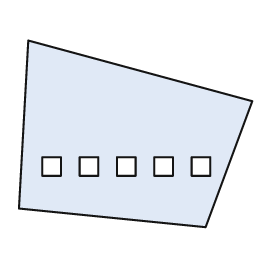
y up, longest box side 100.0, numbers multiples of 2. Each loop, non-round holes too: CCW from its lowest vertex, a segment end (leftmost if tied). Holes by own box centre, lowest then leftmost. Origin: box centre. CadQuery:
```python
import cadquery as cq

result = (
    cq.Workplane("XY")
    .moveTo(30.0, -40.0)
    .lineTo(50.0, 14.0)
    .lineTo(-46.0, 40.0)
    .lineTo(-50.0, -32.0)
    .close()
    .moveTo(-40.0, -18.0)
    .lineTo(-32.0, -18.0)
    .lineTo(-32.0, -10.0)
    .lineTo(-40.0, -10.0)
    .close()
    .moveTo(-24.0, -18.0)
    .lineTo(-16.0, -18.0)
    .lineTo(-16.0, -10.0)
    .lineTo(-24.0, -10.0)
    .close()
    .moveTo(-8.0, -18.0)
    .lineTo(0.0, -18.0)
    .lineTo(0.0, -10.0)
    .lineTo(-8.0, -10.0)
    .close()
    .moveTo(8.0, -18.0)
    .lineTo(16.0, -18.0)
    .lineTo(16.0, -10.0)
    .lineTo(8.0, -10.0)
    .close()
    .moveTo(24.0, -18.0)
    .lineTo(32.0, -18.0)
    .lineTo(32.0, -10.0)
    .lineTo(24.0, -10.0)
    .close()
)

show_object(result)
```